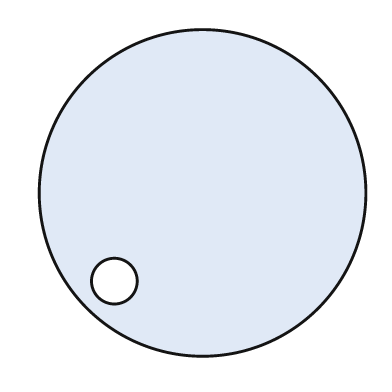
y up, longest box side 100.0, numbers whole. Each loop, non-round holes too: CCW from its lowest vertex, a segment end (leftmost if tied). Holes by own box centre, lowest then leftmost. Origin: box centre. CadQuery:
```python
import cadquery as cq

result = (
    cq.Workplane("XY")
    .moveTo(0.0, 0.0)
    .circle(50.0)
    .moveTo(-27.0, -27.0)
    .circle(7.0)
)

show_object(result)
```